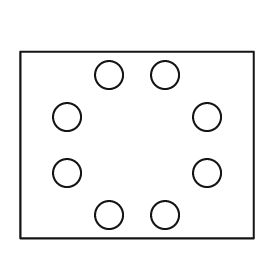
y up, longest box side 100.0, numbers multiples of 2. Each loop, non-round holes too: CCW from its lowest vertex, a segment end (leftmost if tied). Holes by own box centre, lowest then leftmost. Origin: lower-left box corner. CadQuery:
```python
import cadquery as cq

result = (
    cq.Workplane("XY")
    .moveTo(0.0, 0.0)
    .lineTo(100.0, 0.0)
    .lineTo(100.0, 80.0)
    .lineTo(0.0, 80.0)
    .close()
    .moveTo(38.0, 10.0)
    .circle(6.0)
    .moveTo(62.0, 10.0)
    .circle(6.0)
    .moveTo(20.0, 28.0)
    .circle(6.0)
    .moveTo(80.0, 28.0)
    .circle(6.0)
    .moveTo(20.0, 52.0)
    .circle(6.0)
    .moveTo(80.0, 52.0)
    .circle(6.0)
    .moveTo(38.0, 70.0)
    .circle(6.0)
    .moveTo(62.0, 70.0)
    .circle(6.0)
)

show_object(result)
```